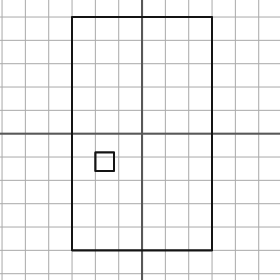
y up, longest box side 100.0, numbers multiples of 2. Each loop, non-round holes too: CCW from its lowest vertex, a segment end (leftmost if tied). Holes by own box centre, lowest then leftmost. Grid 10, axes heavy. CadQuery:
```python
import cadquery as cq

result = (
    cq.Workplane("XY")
    .moveTo(-30.0, -50.0)
    .lineTo(30.0, -50.0)
    .lineTo(30.0, 50.0)
    .lineTo(-30.0, 50.0)
    .close()
    .moveTo(-20.0, -16.0)
    .lineTo(-12.0, -16.0)
    .lineTo(-12.0, -8.0)
    .lineTo(-20.0, -8.0)
    .close()
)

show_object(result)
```